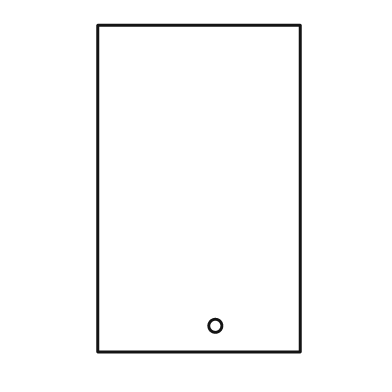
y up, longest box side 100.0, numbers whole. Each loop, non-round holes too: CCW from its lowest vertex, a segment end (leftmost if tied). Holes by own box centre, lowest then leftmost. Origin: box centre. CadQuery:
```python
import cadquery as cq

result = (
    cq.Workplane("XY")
    .moveTo(-31.0, -50.0)
    .lineTo(31.0, -50.0)
    .lineTo(31.0, 50.0)
    .lineTo(-31.0, 50.0)
    .close()
    .moveTo(5.0, -42.0)
    .circle(2.0)
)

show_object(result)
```